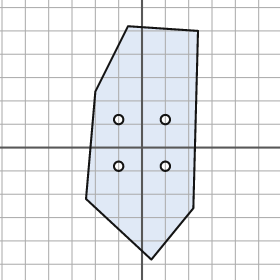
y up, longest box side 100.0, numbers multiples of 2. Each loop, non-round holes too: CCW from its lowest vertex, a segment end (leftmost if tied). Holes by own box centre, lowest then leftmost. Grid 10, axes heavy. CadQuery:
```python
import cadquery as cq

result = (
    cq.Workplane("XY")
    .moveTo(4.0, -48.0)
    .lineTo(22.0, -26.0)
    .lineTo(24.0, 50.0)
    .lineTo(-6.0, 52.0)
    .lineTo(-20.0, 24.0)
    .lineTo(-24.0, -22.0)
    .close()
    .moveTo(-10.0, -8.0)
    .circle(2.0)
    .moveTo(10.0, -8.0)
    .circle(2.0)
    .moveTo(-10.0, 12.0)
    .circle(2.0)
    .moveTo(10.0, 12.0)
    .circle(2.0)
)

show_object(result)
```